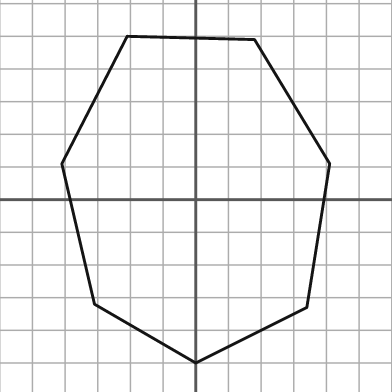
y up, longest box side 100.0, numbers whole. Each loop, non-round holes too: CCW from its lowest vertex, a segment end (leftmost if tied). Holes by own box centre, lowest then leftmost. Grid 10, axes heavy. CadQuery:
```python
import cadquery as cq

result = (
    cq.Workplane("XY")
    .moveTo(0.0, -50.0)
    .lineTo(34.0, -33.0)
    .lineTo(41.0, 11.0)
    .lineTo(18.0, 49.0)
    .lineTo(-21.0, 50.0)
    .lineTo(-41.0, 11.0)
    .lineTo(-31.0, -32.0)
    .close()
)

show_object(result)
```